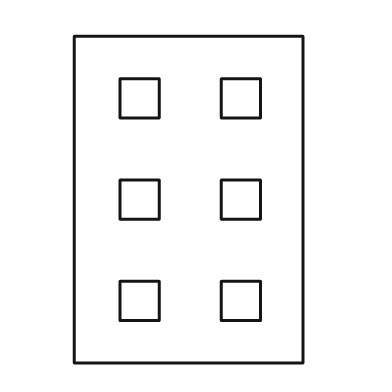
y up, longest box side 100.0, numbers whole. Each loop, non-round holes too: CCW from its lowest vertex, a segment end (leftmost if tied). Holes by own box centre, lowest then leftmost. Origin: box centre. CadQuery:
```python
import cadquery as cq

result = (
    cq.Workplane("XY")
    .moveTo(-35.0, -50.0)
    .lineTo(35.0, -50.0)
    .lineTo(35.0, 50.0)
    .lineTo(-35.0, 50.0)
    .close()
    .moveTo(-21.0, -37.0)
    .lineTo(-9.0, -37.0)
    .lineTo(-9.0, -25.0)
    .lineTo(-21.0, -25.0)
    .close()
    .moveTo(10.0, -37.0)
    .lineTo(22.0, -37.0)
    .lineTo(22.0, -25.0)
    .lineTo(10.0, -25.0)
    .close()
    .moveTo(-21.0, -6.0)
    .lineTo(-9.0, -6.0)
    .lineTo(-9.0, 6.0)
    .lineTo(-21.0, 6.0)
    .close()
    .moveTo(10.0, -6.0)
    .lineTo(22.0, -6.0)
    .lineTo(22.0, 6.0)
    .lineTo(10.0, 6.0)
    .close()
    .moveTo(-21.0, 25.0)
    .lineTo(-9.0, 25.0)
    .lineTo(-9.0, 37.0)
    .lineTo(-21.0, 37.0)
    .close()
    .moveTo(10.0, 25.0)
    .lineTo(22.0, 25.0)
    .lineTo(22.0, 37.0)
    .lineTo(10.0, 37.0)
    .close()
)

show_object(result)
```